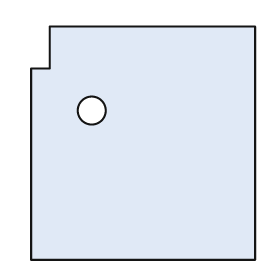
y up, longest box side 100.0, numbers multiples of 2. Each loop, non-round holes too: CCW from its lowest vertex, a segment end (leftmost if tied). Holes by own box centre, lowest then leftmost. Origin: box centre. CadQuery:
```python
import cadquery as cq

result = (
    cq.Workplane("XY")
    .moveTo(-48.0, -50.0)
    .lineTo(48.0, -50.0)
    .lineTo(48.0, 50.0)
    .lineTo(-40.0, 50.0)
    .lineTo(-40.0, 32.0)
    .lineTo(-48.0, 32.0)
    .close()
    .moveTo(-22.0, 14.0)
    .circle(6.0)
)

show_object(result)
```